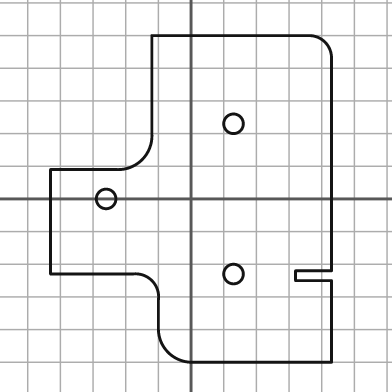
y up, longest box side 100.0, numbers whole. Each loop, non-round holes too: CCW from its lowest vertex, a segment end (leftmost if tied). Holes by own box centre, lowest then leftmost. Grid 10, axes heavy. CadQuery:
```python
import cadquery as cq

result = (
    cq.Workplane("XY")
    .moveTo(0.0, -50.0)
    .lineTo(43.0, -50.0)
    .lineTo(43.0, -25.0)
    .lineTo(32.0, -25.0)
    .lineTo(32.0, -22.0)
    .lineTo(43.0, -22.0)
    .lineTo(43.0, 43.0)
    .threePointArc((41.0, 48.0), (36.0, 50.0))
    .lineTo(-12.0, 50.0)
    .lineTo(-12.0, 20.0)
    .threePointArc((-15.0, 12.0), (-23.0, 9.0))
    .lineTo(-43.0, 9.0)
    .lineTo(-43.0, -23.0)
    .lineTo(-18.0, -23.0)
    .threePointArc((-12.0, -25.0), (-10.0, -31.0))
    .lineTo(-10.0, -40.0)
    .threePointArc((-7.0, -47.0), (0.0, -50.0))
    .close()
    .moveTo(13.0, -23.0)
    .circle(3.0)
    .moveTo(-26.0, 0.0)
    .circle(3.0)
    .moveTo(13.0, 23.0)
    .circle(3.0)
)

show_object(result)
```